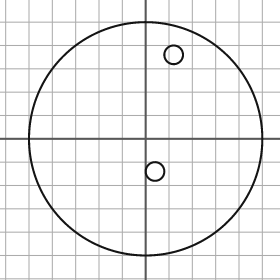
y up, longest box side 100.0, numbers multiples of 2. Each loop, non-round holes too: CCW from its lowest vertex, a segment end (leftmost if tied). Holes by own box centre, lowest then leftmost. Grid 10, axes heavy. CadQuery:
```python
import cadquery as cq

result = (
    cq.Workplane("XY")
    .moveTo(0.0, 0.0)
    .circle(50.0)
    .moveTo(4.0, -14.0)
    .circle(4.0)
    .moveTo(12.0, 36.0)
    .circle(4.0)
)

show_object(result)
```